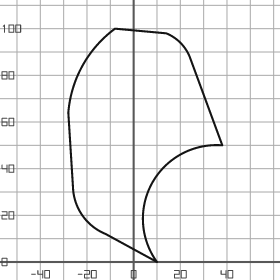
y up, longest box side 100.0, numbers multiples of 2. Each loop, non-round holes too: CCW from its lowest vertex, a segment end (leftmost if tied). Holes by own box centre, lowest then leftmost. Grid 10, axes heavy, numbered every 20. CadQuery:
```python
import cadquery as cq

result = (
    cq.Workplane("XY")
    .moveTo(10.0, 0.0)
    .threePointArc((8.0, 34.0), (38.0, 50.0))
    .lineTo(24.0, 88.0)
    .threePointArc((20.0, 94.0), (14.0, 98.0))
    .lineTo(-8.0, 100.0)
    .threePointArc((-22.0, 84.0), (-28.0, 64.0))
    .lineTo(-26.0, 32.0)
    .threePointArc((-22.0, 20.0), (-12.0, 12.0))
    .close()
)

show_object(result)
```